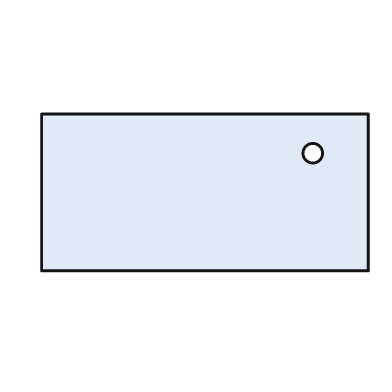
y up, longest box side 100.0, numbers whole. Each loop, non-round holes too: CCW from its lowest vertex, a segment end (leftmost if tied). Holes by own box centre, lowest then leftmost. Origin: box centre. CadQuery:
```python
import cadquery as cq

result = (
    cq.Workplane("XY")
    .moveTo(-50.0, -24.0)
    .lineTo(50.0, -24.0)
    .lineTo(50.0, 24.0)
    .lineTo(-50.0, 24.0)
    .close()
    .moveTo(33.0, 12.0)
    .circle(3.0)
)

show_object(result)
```